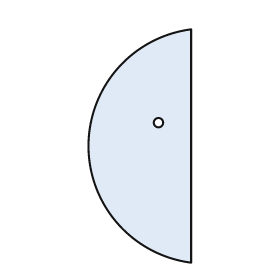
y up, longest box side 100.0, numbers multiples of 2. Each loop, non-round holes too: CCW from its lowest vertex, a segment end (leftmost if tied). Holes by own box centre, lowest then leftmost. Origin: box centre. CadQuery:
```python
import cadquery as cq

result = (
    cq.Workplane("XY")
    .moveTo(22.0, -50.0)
    .lineTo(22.0, 50.0)
    .threePointArc((-22.0, 0.0), (22.0, -50.0))
    .close()
    .moveTo(8.0, 10.0)
    .circle(2.0)
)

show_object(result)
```